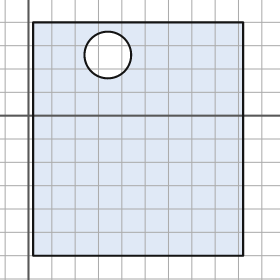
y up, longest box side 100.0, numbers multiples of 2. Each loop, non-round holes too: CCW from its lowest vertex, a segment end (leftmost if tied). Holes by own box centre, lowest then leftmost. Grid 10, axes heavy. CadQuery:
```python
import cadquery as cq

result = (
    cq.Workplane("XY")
    .moveTo(2.0, -60.0)
    .lineTo(92.0, -60.0)
    .lineTo(92.0, 40.0)
    .lineTo(2.0, 40.0)
    .close()
    .moveTo(34.0, 26.0)
    .circle(10.0)
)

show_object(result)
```